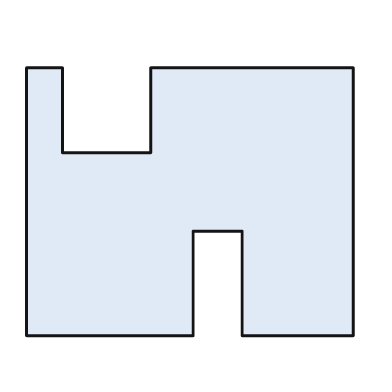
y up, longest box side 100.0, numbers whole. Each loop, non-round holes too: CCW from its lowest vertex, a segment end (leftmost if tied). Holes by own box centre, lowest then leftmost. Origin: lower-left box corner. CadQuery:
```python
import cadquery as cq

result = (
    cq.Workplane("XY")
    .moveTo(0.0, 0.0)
    .lineTo(51.0, 0.0)
    .lineTo(51.0, 32.0)
    .lineTo(66.0, 32.0)
    .lineTo(66.0, 0.0)
    .lineTo(100.0, 0.0)
    .lineTo(100.0, 82.0)
    .lineTo(38.0, 82.0)
    .lineTo(38.0, 56.0)
    .lineTo(11.0, 56.0)
    .lineTo(11.0, 82.0)
    .lineTo(0.0, 82.0)
    .close()
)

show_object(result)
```